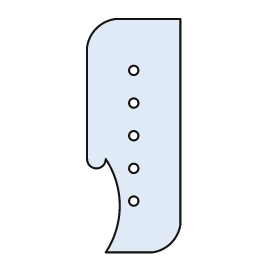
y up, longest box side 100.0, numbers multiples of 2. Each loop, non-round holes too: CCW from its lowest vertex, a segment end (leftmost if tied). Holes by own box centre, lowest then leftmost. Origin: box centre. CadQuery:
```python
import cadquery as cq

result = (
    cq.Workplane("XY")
    .moveTo(-12.0, -50.0)
    .lineTo(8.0, -50.0)
    .threePointArc((16.0, -46.0), (20.0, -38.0))
    .lineTo(20.0, 50.0)
    .lineTo(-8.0, 50.0)
    .threePointArc((-16.0, 46.0), (-20.0, 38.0))
    .lineTo(-20.0, -10.0)
    .threePointArc((-16.0, -14.0), (-12.0, -10.0))
    .threePointArc((-6.0, -30.0), (-12.0, -50.0))
    .close()
    .moveTo(0.0, -28.0)
    .circle(2.0)
    .moveTo(0.0, -14.0)
    .circle(2.0)
    .moveTo(0.0, 0.0)
    .circle(2.0)
    .moveTo(0.0, 14.0)
    .circle(2.0)
    .moveTo(0.0, 28.0)
    .circle(2.0)
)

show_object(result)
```